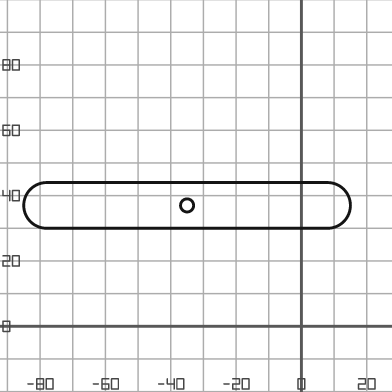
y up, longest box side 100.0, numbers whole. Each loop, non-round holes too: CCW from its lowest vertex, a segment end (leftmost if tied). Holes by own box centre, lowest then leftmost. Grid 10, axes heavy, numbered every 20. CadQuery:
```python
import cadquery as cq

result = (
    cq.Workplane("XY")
    .moveTo(-78.0, 30.0)
    .lineTo(8.0, 30.0)
    .threePointArc((15.0, 37.0), (8.0, 44.0))
    .lineTo(-78.0, 44.0)
    .threePointArc((-85.0, 37.0), (-78.0, 30.0))
    .close()
    .moveTo(-35.0, 37.0)
    .circle(2.0)
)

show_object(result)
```